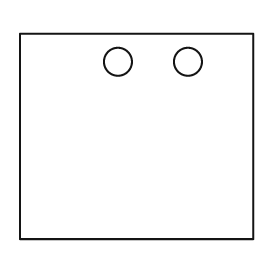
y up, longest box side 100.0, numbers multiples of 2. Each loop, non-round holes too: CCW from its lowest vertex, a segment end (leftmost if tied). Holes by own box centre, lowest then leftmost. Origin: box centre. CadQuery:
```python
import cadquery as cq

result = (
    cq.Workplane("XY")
    .moveTo(-50.0, -44.0)
    .lineTo(50.0, -44.0)
    .lineTo(50.0, 44.0)
    .lineTo(-50.0, 44.0)
    .close()
    .moveTo(-8.0, 32.0)
    .circle(6.0)
    .moveTo(22.0, 32.0)
    .circle(6.0)
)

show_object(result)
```